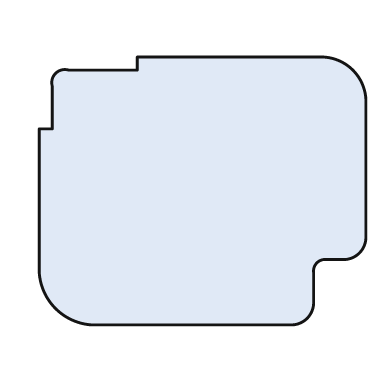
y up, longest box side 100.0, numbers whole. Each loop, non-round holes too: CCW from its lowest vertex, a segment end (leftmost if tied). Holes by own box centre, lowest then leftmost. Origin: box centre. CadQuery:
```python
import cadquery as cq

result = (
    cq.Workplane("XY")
    .moveTo(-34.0, -41.0)
    .lineTo(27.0, -41.0)
    .threePointArc((32.0, -39.0), (34.0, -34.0))
    .lineTo(34.0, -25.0)
    .threePointArc((35.0, -22.0), (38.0, -21.0))
    .lineTo(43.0, -21.0)
    .threePointArc((48.0, -19.0), (50.0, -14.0))
    .lineTo(50.0, 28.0)
    .threePointArc((46.0, 37.0), (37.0, 41.0))
    .lineTo(-20.0, 41.0)
    .lineTo(-20.0, 37.0)
    .lineTo(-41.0, 37.0)
    .threePointArc((-45.0, 36.0), (-46.0, 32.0))
    .lineTo(-46.0, 19.0)
    .lineTo(-50.0, 19.0)
    .lineTo(-50.0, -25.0)
    .threePointArc((-45.0, -36.0), (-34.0, -41.0))
    .close()
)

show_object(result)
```